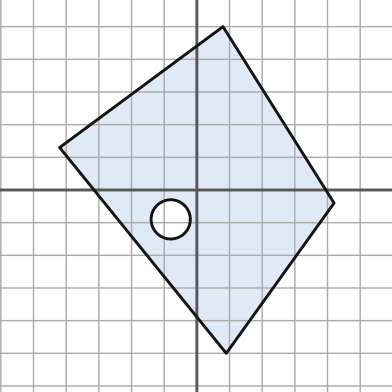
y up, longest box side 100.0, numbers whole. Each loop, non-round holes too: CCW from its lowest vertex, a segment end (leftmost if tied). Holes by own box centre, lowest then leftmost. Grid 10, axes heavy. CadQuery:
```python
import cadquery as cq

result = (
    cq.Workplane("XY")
    .moveTo(9.0, -50.0)
    .lineTo(42.0, -4.0)
    .lineTo(8.0, 50.0)
    .lineTo(-42.0, 13.0)
    .close()
    .moveTo(-8.0, -9.0)
    .circle(6.0)
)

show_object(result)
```